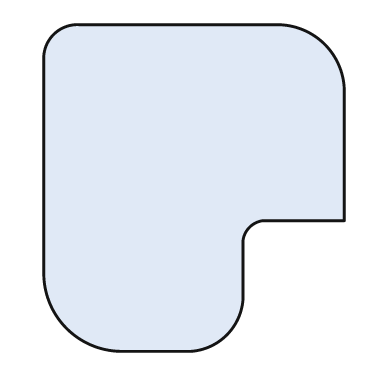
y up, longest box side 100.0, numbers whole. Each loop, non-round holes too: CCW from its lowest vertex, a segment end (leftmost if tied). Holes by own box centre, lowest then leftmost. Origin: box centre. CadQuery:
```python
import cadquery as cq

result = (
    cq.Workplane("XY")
    .moveTo(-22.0, -50.0)
    .lineTo(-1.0, -50.0)
    .threePointArc((10.0, -45.0), (15.0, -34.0))
    .lineTo(15.0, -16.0)
    .threePointArc((17.0, -12.0), (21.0, -10.0))
    .lineTo(46.0, -10.0)
    .lineTo(46.0, 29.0)
    .threePointArc((40.0, 44.0), (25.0, 50.0))
    .lineTo(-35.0, 50.0)
    .threePointArc((-43.0, 47.0), (-46.0, 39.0))
    .lineTo(-46.0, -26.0)
    .threePointArc((-39.0, -43.0), (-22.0, -50.0))
    .close()
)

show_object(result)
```